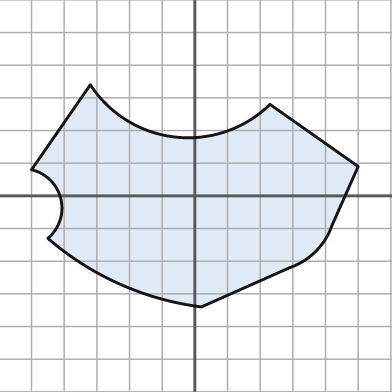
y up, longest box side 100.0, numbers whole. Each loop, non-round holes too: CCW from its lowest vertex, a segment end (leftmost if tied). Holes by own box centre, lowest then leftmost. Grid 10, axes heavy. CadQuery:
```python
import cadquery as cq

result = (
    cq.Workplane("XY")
    .moveTo(2.0, -34.0)
    .lineTo(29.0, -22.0)
    .threePointArc((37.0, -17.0), (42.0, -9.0))
    .lineTo(50.0, 9.0)
    .lineTo(23.0, 28.0)
    .threePointArc((-6.0, 18.0), (-32.0, 34.0))
    .lineTo(-50.0, 8.0)
    .threePointArc((-41.0, -1.0), (-45.0, -13.0))
    .threePointArc((-23.0, -27.0), (2.0, -34.0))
    .close()
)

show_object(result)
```